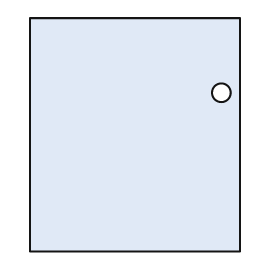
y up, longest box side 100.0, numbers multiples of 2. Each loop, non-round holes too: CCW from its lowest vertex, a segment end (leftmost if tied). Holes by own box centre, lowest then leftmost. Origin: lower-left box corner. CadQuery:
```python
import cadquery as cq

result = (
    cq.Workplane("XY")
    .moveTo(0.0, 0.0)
    .lineTo(90.0, 0.0)
    .lineTo(90.0, 100.0)
    .lineTo(0.0, 100.0)
    .close()
    .moveTo(82.0, 68.0)
    .circle(4.0)
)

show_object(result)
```